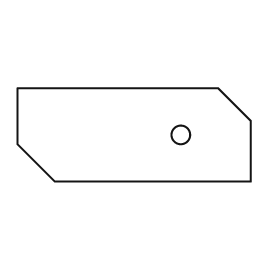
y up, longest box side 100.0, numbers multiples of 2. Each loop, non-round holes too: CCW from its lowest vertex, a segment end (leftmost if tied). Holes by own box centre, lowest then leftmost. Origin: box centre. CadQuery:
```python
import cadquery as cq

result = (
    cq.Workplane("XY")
    .moveTo(-34.0, -20.0)
    .lineTo(50.0, -20.0)
    .lineTo(50.0, 6.0)
    .lineTo(36.0, 20.0)
    .lineTo(-50.0, 20.0)
    .lineTo(-50.0, -4.0)
    .close()
    .moveTo(20.0, 0.0)
    .circle(4.0)
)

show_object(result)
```